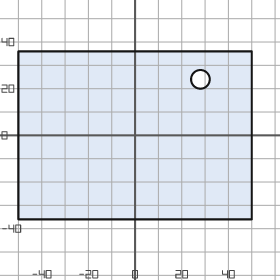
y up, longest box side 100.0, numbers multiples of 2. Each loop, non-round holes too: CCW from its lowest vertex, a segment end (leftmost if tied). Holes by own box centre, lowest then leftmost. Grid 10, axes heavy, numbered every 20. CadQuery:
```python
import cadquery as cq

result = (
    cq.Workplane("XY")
    .moveTo(-50.0, -36.0)
    .lineTo(50.0, -36.0)
    .lineTo(50.0, 36.0)
    .lineTo(-50.0, 36.0)
    .close()
    .moveTo(28.0, 24.0)
    .circle(4.0)
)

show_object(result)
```